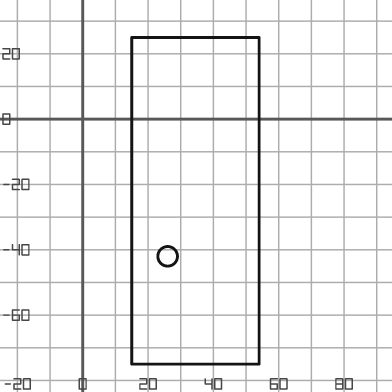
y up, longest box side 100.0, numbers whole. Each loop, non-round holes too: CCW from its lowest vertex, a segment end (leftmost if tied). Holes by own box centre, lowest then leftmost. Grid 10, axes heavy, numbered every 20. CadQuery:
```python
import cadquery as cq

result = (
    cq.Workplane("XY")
    .moveTo(15.0, -75.0)
    .lineTo(54.0, -75.0)
    .lineTo(54.0, 25.0)
    .lineTo(15.0, 25.0)
    .close()
    .moveTo(26.0, -42.0)
    .circle(3.0)
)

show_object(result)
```